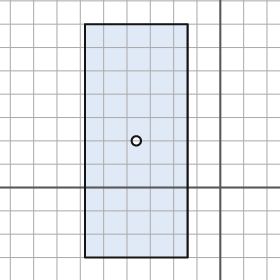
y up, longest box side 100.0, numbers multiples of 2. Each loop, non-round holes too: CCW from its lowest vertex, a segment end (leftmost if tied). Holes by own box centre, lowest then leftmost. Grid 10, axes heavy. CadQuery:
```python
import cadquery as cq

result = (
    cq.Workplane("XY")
    .moveTo(-58.0, -30.0)
    .lineTo(-14.0, -30.0)
    .lineTo(-14.0, 70.0)
    .lineTo(-58.0, 70.0)
    .close()
    .moveTo(-36.0, 20.0)
    .circle(2.0)
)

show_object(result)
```